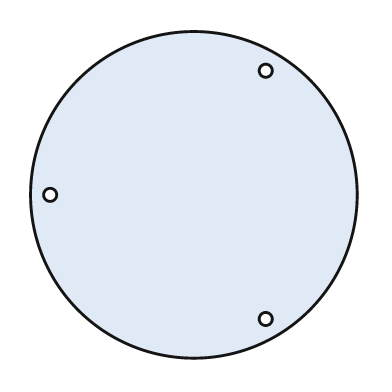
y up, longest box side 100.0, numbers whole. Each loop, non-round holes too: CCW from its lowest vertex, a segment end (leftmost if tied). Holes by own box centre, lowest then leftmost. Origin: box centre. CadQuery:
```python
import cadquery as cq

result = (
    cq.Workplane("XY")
    .moveTo(0.0, 0.0)
    .circle(50.0)
    .moveTo(22.0, -38.0)
    .circle(2.0)
    .moveTo(-44.0, 0.0)
    .circle(2.0)
    .moveTo(22.0, 38.0)
    .circle(2.0)
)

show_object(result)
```